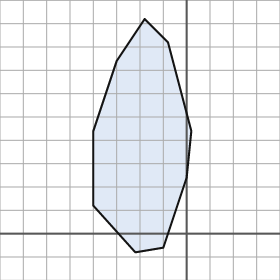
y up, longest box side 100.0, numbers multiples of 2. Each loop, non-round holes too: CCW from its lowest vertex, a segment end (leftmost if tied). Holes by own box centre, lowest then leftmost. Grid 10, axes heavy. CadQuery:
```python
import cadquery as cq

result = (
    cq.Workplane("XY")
    .moveTo(-22.0, -8.0)
    .lineTo(-10.0, -6.0)
    .lineTo(0.0, 24.0)
    .lineTo(2.0, 44.0)
    .lineTo(-8.0, 82.0)
    .lineTo(-18.0, 92.0)
    .lineTo(-30.0, 74.0)
    .lineTo(-40.0, 44.0)
    .lineTo(-40.0, 12.0)
    .close()
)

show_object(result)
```